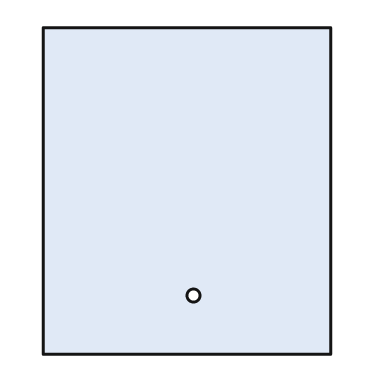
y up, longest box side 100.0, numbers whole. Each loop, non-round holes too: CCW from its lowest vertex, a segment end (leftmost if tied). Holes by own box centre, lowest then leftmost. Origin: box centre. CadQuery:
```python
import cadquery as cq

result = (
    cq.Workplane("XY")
    .moveTo(-44.0, -50.0)
    .lineTo(44.0, -50.0)
    .lineTo(44.0, 50.0)
    .lineTo(-44.0, 50.0)
    .close()
    .moveTo(2.0, -32.0)
    .circle(2.0)
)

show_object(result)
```